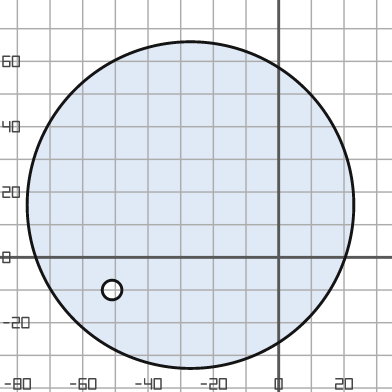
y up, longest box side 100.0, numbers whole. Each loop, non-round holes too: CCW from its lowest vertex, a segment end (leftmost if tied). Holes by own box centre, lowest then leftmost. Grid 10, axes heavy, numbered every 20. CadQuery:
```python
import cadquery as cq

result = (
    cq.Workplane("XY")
    .moveTo(-27.0, 16.0)
    .circle(50.0)
    .moveTo(-51.0, -10.0)
    .circle(3.0)
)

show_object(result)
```